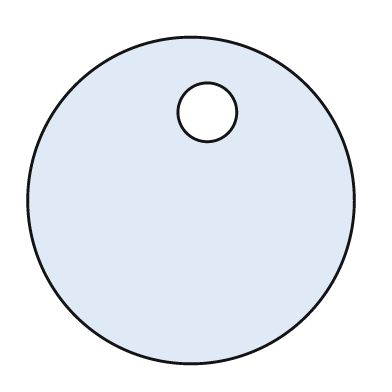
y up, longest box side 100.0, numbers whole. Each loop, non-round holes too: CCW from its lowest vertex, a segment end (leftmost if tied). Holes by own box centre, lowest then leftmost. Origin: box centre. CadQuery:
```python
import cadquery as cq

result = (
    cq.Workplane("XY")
    .moveTo(0.0, 0.0)
    .circle(50.0)
    .moveTo(5.0, 27.0)
    .circle(9.0)
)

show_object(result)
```